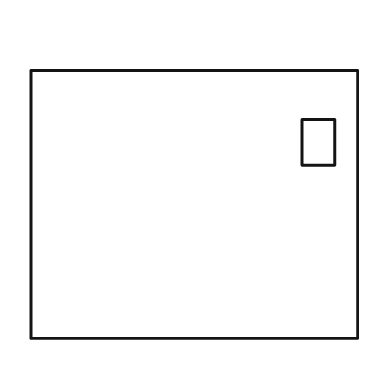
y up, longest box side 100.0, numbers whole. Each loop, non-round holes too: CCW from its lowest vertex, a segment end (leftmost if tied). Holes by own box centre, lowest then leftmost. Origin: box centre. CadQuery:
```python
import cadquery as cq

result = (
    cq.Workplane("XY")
    .moveTo(-50.0, -41.0)
    .lineTo(50.0, -41.0)
    .lineTo(50.0, 41.0)
    .lineTo(-50.0, 41.0)
    .close()
    .moveTo(33.0, 12.0)
    .lineTo(43.0, 12.0)
    .lineTo(43.0, 26.0)
    .lineTo(33.0, 26.0)
    .close()
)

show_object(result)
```